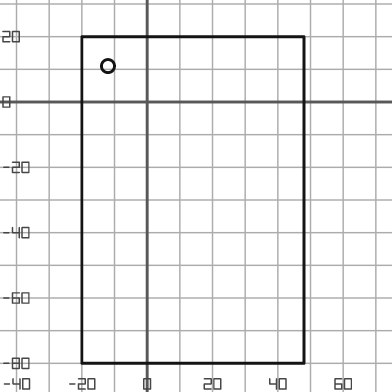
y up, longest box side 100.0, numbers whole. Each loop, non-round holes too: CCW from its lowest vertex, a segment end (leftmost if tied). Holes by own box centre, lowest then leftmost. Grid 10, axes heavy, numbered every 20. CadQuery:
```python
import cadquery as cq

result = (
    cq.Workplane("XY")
    .moveTo(-20.0, -80.0)
    .lineTo(48.0, -80.0)
    .lineTo(48.0, 20.0)
    .lineTo(-20.0, 20.0)
    .close()
    .moveTo(-12.0, 11.0)
    .circle(2.0)
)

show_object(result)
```